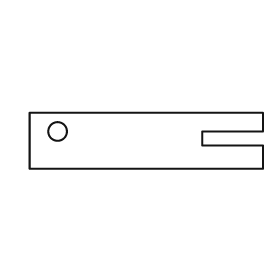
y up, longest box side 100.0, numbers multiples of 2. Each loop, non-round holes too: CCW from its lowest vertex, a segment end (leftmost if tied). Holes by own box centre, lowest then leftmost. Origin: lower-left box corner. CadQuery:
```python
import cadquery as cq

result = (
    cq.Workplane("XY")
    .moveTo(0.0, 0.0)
    .lineTo(100.0, 0.0)
    .lineTo(100.0, 10.0)
    .lineTo(74.0, 10.0)
    .lineTo(74.0, 16.0)
    .lineTo(100.0, 16.0)
    .lineTo(100.0, 24.0)
    .lineTo(0.0, 24.0)
    .close()
    .moveTo(12.0, 16.0)
    .circle(4.0)
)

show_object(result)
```